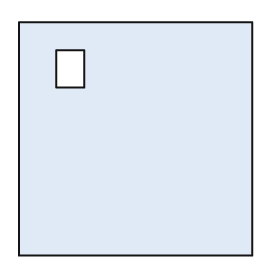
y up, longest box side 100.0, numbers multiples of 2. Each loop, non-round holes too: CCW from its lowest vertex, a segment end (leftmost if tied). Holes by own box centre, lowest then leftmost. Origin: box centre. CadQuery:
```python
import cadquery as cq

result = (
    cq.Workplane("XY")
    .moveTo(-50.0, -50.0)
    .lineTo(50.0, -50.0)
    .lineTo(50.0, 50.0)
    .lineTo(-50.0, 50.0)
    .close()
    .moveTo(-34.0, 22.0)
    .lineTo(-22.0, 22.0)
    .lineTo(-22.0, 38.0)
    .lineTo(-34.0, 38.0)
    .close()
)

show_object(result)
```